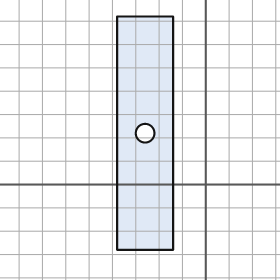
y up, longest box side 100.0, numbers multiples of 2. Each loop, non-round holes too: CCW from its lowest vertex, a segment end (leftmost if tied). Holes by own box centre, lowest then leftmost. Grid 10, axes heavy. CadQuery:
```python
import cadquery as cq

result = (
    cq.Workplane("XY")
    .moveTo(-38.0, -28.0)
    .lineTo(-14.0, -28.0)
    .lineTo(-14.0, 72.0)
    .lineTo(-38.0, 72.0)
    .close()
    .moveTo(-26.0, 22.0)
    .circle(4.0)
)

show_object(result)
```